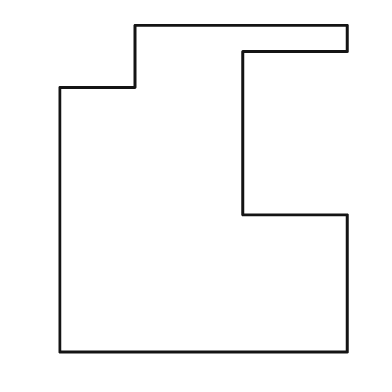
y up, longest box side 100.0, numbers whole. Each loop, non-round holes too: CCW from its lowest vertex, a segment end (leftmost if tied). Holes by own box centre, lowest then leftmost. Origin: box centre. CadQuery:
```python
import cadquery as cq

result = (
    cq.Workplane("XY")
    .moveTo(-44.0, -50.0)
    .lineTo(44.0, -50.0)
    .lineTo(44.0, -8.0)
    .lineTo(12.0, -8.0)
    .lineTo(12.0, 42.0)
    .lineTo(44.0, 42.0)
    .lineTo(44.0, 50.0)
    .lineTo(-21.0, 50.0)
    .lineTo(-21.0, 31.0)
    .lineTo(-44.0, 31.0)
    .close()
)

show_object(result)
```